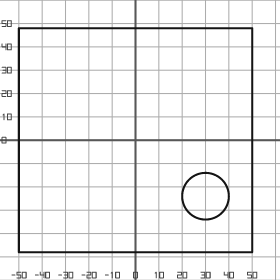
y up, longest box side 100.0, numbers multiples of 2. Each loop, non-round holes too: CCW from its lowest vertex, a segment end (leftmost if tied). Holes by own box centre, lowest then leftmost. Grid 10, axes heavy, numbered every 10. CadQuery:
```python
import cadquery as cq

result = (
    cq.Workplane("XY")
    .moveTo(-50.0, -48.0)
    .lineTo(50.0, -48.0)
    .lineTo(50.0, 48.0)
    .lineTo(-50.0, 48.0)
    .close()
    .moveTo(30.0, -24.0)
    .circle(10.0)
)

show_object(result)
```